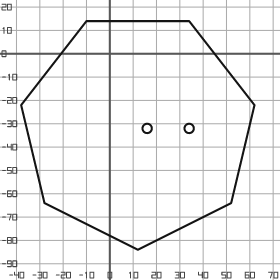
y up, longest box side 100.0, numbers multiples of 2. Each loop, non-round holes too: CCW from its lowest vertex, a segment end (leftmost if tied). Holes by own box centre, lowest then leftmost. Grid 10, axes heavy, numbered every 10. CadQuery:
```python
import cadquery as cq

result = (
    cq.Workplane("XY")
    .moveTo(12.0, -84.0)
    .lineTo(52.0, -64.0)
    .lineTo(62.0, -22.0)
    .lineTo(34.0, 14.0)
    .lineTo(-10.0, 14.0)
    .lineTo(-38.0, -22.0)
    .lineTo(-28.0, -64.0)
    .close()
    .moveTo(16.0, -32.0)
    .circle(2.0)
    .moveTo(34.0, -32.0)
    .circle(2.0)
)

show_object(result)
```